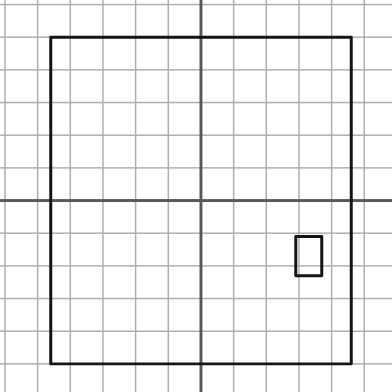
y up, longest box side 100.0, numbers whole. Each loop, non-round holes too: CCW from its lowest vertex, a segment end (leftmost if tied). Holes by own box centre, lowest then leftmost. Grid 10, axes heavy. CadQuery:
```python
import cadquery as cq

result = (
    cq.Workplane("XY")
    .moveTo(-46.0, -50.0)
    .lineTo(46.0, -50.0)
    .lineTo(46.0, 50.0)
    .lineTo(-46.0, 50.0)
    .close()
    .moveTo(29.0, -23.0)
    .lineTo(37.0, -23.0)
    .lineTo(37.0, -11.0)
    .lineTo(29.0, -11.0)
    .close()
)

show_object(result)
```